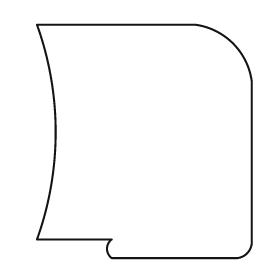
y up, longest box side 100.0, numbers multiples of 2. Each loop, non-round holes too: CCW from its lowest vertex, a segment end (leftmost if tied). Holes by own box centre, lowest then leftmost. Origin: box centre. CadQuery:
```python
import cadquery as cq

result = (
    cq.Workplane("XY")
    .moveTo(-14.0, -50.0)
    .lineTo(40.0, -50.0)
    .threePointArc((44.0, -48.0), (46.0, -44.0))
    .lineTo(46.0, 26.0)
    .threePointArc((38.0, 42.0), (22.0, 50.0))
    .lineTo(-46.0, 50.0)
    .threePointArc((-38.0, 4.0), (-46.0, -42.0))
    .lineTo(-14.0, -42.0)
    .threePointArc((-16.0, -46.0), (-14.0, -50.0))
    .close()
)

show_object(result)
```